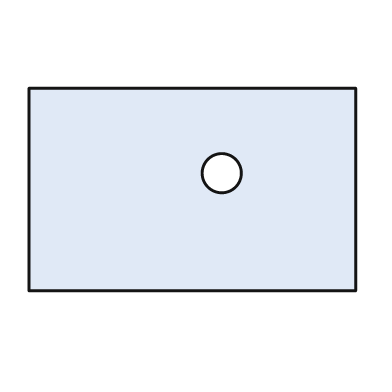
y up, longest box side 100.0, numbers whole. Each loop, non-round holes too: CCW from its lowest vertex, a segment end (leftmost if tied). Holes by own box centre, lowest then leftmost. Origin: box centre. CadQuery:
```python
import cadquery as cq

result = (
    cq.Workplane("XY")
    .moveTo(-50.0, -31.0)
    .lineTo(50.0, -31.0)
    .lineTo(50.0, 31.0)
    .lineTo(-50.0, 31.0)
    .close()
    .moveTo(9.0, 5.0)
    .circle(6.0)
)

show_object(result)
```